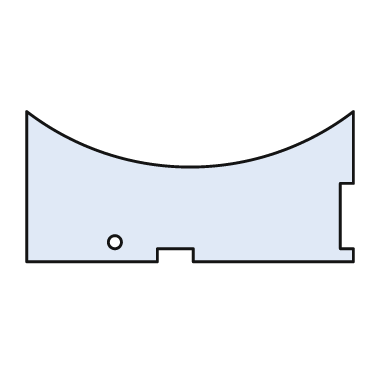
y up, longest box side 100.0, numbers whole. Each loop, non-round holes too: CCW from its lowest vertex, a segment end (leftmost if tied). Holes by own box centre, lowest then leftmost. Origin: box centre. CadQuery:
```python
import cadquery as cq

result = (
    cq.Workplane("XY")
    .moveTo(-50.0, -23.0)
    .lineTo(-10.0, -23.0)
    .lineTo(-10.0, -19.0)
    .lineTo(1.0, -19.0)
    .lineTo(1.0, -23.0)
    .lineTo(50.0, -23.0)
    .lineTo(50.0, -19.0)
    .lineTo(46.0, -19.0)
    .lineTo(46.0, 1.0)
    .lineTo(50.0, 1.0)
    .lineTo(50.0, 23.0)
    .threePointArc((0.0, 6.0), (-50.0, 23.0))
    .close()
    .moveTo(-23.0, -17.0)
    .circle(2.0)
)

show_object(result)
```